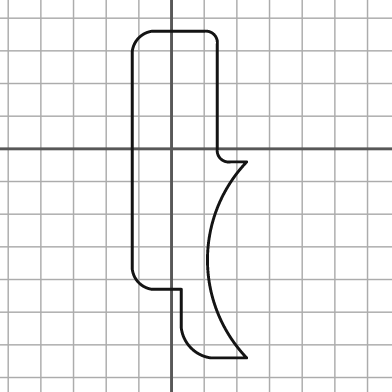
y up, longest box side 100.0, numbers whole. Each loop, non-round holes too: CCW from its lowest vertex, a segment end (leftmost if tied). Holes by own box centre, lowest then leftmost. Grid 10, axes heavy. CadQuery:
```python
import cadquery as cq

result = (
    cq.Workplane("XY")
    .moveTo(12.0, -64.0)
    .lineTo(23.0, -64.0)
    .threePointArc((11.0, -34.0), (23.0, -4.0))
    .lineTo(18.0, -4.0)
    .threePointArc((15.0, -3.0), (14.0, 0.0))
    .lineTo(14.0, 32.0)
    .threePointArc((13.0, 35.0), (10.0, 36.0))
    .lineTo(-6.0, 36.0)
    .threePointArc((-10.0, 34.0), (-12.0, 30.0))
    .lineTo(-12.0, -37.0)
    .threePointArc((-10.0, -41.0), (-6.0, -43.0))
    .lineTo(3.0, -43.0)
    .lineTo(3.0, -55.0)
    .threePointArc((6.0, -61.0), (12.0, -64.0))
    .close()
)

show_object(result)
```